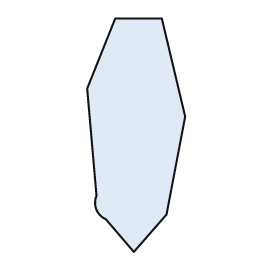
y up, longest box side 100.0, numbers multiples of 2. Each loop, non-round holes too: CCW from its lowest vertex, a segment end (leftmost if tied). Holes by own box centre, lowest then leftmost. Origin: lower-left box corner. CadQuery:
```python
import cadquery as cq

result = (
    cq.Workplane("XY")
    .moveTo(20.0, 0.0)
    .lineTo(34.0, 16.0)
    .lineTo(42.0, 58.0)
    .lineTo(32.0, 100.0)
    .lineTo(12.0, 100.0)
    .lineTo(0.0, 70.0)
    .lineTo(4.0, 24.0)
    .threePointArc((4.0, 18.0), (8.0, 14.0))
    .close()
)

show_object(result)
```